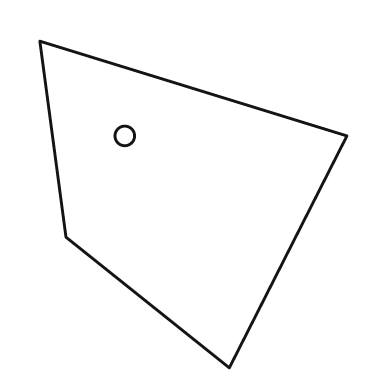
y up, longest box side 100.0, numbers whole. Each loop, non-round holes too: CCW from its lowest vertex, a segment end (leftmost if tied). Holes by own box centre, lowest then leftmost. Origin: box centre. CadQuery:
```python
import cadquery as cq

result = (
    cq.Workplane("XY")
    .moveTo(11.0, -50.0)
    .lineTo(47.0, 21.0)
    .lineTo(-47.0, 50.0)
    .lineTo(-39.0, -10.0)
    .close()
    .moveTo(-21.0, 21.0)
    .circle(3.0)
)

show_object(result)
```